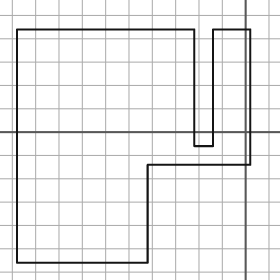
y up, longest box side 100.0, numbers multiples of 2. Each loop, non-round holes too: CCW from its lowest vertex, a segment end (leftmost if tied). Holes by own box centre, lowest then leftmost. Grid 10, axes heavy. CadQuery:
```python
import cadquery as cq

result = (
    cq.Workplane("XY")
    .moveTo(-98.0, -56.0)
    .lineTo(-42.0, -56.0)
    .lineTo(-42.0, -14.0)
    .lineTo(2.0, -14.0)
    .lineTo(2.0, 44.0)
    .lineTo(-14.0, 44.0)
    .lineTo(-14.0, -6.0)
    .lineTo(-22.0, -6.0)
    .lineTo(-22.0, 44.0)
    .lineTo(-98.0, 44.0)
    .close()
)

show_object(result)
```